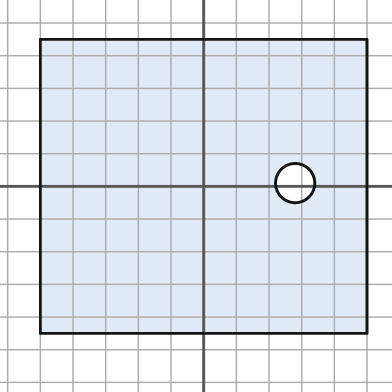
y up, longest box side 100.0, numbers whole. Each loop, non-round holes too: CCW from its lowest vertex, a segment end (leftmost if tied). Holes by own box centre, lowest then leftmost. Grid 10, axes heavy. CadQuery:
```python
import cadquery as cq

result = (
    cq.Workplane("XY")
    .moveTo(-50.0, -45.0)
    .lineTo(50.0, -45.0)
    .lineTo(50.0, 45.0)
    .lineTo(-50.0, 45.0)
    .close()
    .moveTo(28.0, 1.0)
    .circle(6.0)
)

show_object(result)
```